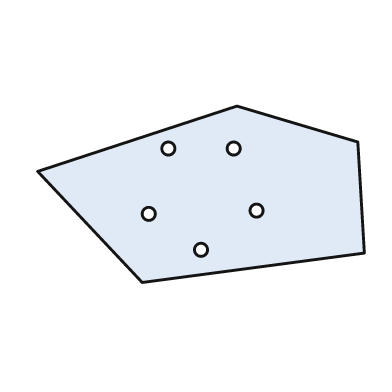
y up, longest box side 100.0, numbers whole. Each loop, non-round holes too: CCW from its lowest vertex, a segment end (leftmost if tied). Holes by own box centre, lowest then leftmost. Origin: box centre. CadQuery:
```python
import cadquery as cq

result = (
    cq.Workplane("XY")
    .moveTo(-18.0, -27.0)
    .lineTo(50.0, -18.0)
    .lineTo(48.0, 16.0)
    .lineTo(11.0, 27.0)
    .lineTo(-50.0, 7.0)
    .close()
    .moveTo(0.0, -17.0)
    .circle(2.0)
    .moveTo(-16.0, -6.0)
    .circle(2.0)
    .moveTo(17.0, -5.0)
    .circle(2.0)
    .moveTo(-10.0, 14.0)
    .circle(2.0)
    .moveTo(10.0, 14.0)
    .circle(2.0)
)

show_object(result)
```